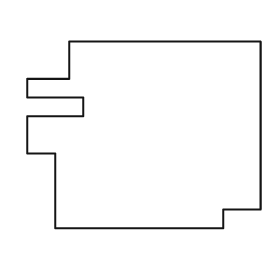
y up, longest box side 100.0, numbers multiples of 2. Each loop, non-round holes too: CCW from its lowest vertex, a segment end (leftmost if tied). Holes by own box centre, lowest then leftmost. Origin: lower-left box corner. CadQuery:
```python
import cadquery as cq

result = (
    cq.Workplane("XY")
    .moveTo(12.0, 0.0)
    .lineTo(84.0, 0.0)
    .lineTo(84.0, 8.0)
    .lineTo(100.0, 8.0)
    .lineTo(100.0, 80.0)
    .lineTo(18.0, 80.0)
    .lineTo(18.0, 64.0)
    .lineTo(0.0, 64.0)
    .lineTo(0.0, 56.0)
    .lineTo(24.0, 56.0)
    .lineTo(24.0, 48.0)
    .lineTo(0.0, 48.0)
    .lineTo(0.0, 32.0)
    .lineTo(12.0, 32.0)
    .close()
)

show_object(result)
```